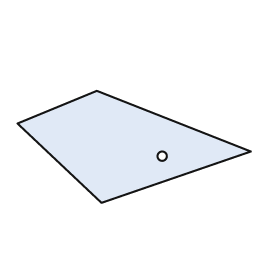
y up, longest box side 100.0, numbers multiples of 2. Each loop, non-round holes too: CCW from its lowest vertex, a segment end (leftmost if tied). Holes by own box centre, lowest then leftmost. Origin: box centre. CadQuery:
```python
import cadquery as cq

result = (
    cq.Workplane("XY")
    .moveTo(-14.0, -24.0)
    .lineTo(50.0, -2.0)
    .lineTo(-16.0, 24.0)
    .lineTo(-50.0, 10.0)
    .close()
    .moveTo(12.0, -4.0)
    .circle(2.0)
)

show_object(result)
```